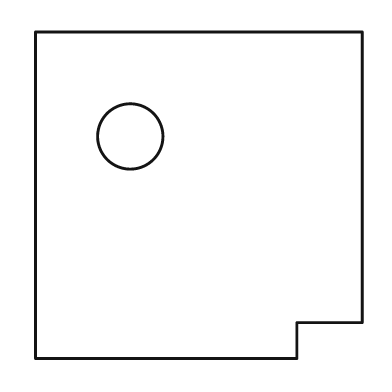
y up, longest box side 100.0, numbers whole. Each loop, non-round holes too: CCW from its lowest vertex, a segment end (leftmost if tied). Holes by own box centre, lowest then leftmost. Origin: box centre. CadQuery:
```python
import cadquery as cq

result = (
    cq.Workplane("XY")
    .moveTo(-50.0, -50.0)
    .lineTo(30.0, -50.0)
    .lineTo(30.0, -39.0)
    .lineTo(50.0, -39.0)
    .lineTo(50.0, 50.0)
    .lineTo(-50.0, 50.0)
    .close()
    .moveTo(-21.0, 18.0)
    .circle(10.0)
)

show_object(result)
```